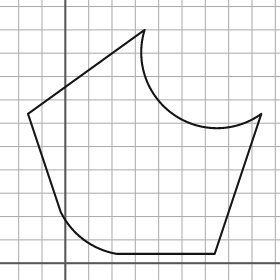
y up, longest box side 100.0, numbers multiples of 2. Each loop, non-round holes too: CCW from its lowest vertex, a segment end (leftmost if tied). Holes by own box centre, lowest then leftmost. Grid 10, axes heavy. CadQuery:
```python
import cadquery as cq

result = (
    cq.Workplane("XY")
    .moveTo(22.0, 4.0)
    .lineTo(64.0, 4.0)
    .lineTo(84.0, 64.0)
    .threePointArc((46.0, 64.0), (34.0, 100.0))
    .lineTo(-16.0, 64.0)
    .lineTo(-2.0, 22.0)
    .threePointArc((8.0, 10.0), (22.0, 4.0))
    .close()
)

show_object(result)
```